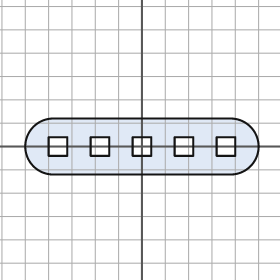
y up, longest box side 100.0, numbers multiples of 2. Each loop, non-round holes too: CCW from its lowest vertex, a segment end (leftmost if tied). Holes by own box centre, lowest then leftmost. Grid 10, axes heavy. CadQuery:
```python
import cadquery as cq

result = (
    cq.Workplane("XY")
    .moveTo(-38.0, -12.0)
    .lineTo(38.0, -12.0)
    .threePointArc((50.0, 0.0), (38.0, 12.0))
    .lineTo(-38.0, 12.0)
    .threePointArc((-50.0, 0.0), (-38.0, -12.0))
    .close()
    .moveTo(-40.0, -4.0)
    .lineTo(-32.0, -4.0)
    .lineTo(-32.0, 4.0)
    .lineTo(-40.0, 4.0)
    .close()
    .moveTo(-22.0, -4.0)
    .lineTo(-14.0, -4.0)
    .lineTo(-14.0, 4.0)
    .lineTo(-22.0, 4.0)
    .close()
    .moveTo(-4.0, -4.0)
    .lineTo(4.0, -4.0)
    .lineTo(4.0, 4.0)
    .lineTo(-4.0, 4.0)
    .close()
    .moveTo(14.0, -4.0)
    .lineTo(22.0, -4.0)
    .lineTo(22.0, 4.0)
    .lineTo(14.0, 4.0)
    .close()
    .moveTo(32.0, -4.0)
    .lineTo(40.0, -4.0)
    .lineTo(40.0, 4.0)
    .lineTo(32.0, 4.0)
    .close()
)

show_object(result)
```